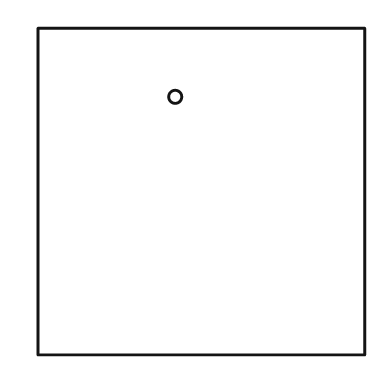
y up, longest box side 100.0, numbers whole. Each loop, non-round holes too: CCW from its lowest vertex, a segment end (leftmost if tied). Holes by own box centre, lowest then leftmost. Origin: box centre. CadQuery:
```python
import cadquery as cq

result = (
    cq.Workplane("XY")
    .moveTo(-50.0, -50.0)
    .lineTo(50.0, -50.0)
    .lineTo(50.0, 50.0)
    .lineTo(-50.0, 50.0)
    .close()
    .moveTo(-8.0, 29.0)
    .circle(2.0)
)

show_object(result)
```